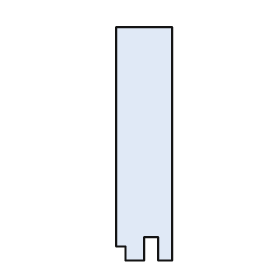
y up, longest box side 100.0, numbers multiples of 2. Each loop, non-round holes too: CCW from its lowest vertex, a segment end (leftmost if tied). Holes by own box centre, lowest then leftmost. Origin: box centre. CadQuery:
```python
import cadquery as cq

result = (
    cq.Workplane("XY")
    .moveTo(-8.0, -50.0)
    .lineTo(0.0, -50.0)
    .lineTo(0.0, -40.0)
    .lineTo(6.0, -40.0)
    .lineTo(6.0, -50.0)
    .lineTo(12.0, -50.0)
    .lineTo(12.0, 50.0)
    .lineTo(-12.0, 50.0)
    .lineTo(-12.0, -44.0)
    .lineTo(-8.0, -44.0)
    .close()
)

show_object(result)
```